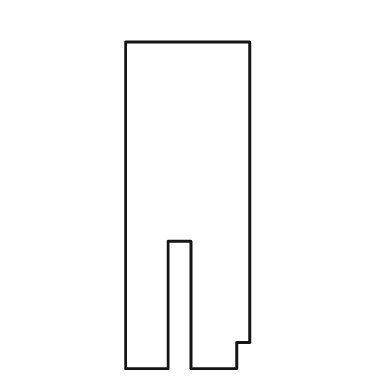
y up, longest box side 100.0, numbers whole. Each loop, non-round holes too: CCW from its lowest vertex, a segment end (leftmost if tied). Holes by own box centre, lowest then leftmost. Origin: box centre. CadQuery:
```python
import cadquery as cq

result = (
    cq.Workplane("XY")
    .moveTo(-19.0, -50.0)
    .lineTo(-6.0, -50.0)
    .lineTo(-6.0, -11.0)
    .lineTo(1.0, -11.0)
    .lineTo(1.0, -50.0)
    .lineTo(15.0, -50.0)
    .lineTo(15.0, -42.0)
    .lineTo(19.0, -42.0)
    .lineTo(19.0, 50.0)
    .lineTo(-19.0, 50.0)
    .close()
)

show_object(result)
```